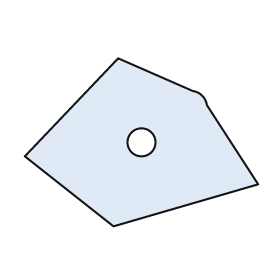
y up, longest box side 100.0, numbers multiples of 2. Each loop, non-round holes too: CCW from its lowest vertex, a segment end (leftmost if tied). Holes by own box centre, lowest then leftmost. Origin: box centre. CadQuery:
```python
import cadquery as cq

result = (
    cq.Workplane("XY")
    .moveTo(-12.0, -36.0)
    .lineTo(50.0, -18.0)
    .lineTo(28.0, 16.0)
    .threePointArc((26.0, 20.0), (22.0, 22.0))
    .lineTo(-10.0, 36.0)
    .lineTo(-50.0, -6.0)
    .close()
    .moveTo(0.0, 0.0)
    .circle(6.0)
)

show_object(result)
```